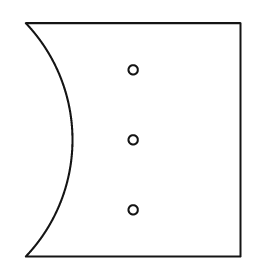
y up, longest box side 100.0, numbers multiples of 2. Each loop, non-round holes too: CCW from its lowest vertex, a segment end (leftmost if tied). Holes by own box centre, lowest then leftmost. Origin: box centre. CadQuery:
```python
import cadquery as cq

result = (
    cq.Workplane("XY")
    .moveTo(-46.0, -50.0)
    .lineTo(46.0, -50.0)
    .lineTo(46.0, 50.0)
    .lineTo(-46.0, 50.0)
    .threePointArc((-26.0, 0.0), (-46.0, -50.0))
    .close()
    .moveTo(0.0, -30.0)
    .circle(2.0)
    .moveTo(0.0, 0.0)
    .circle(2.0)
    .moveTo(0.0, 30.0)
    .circle(2.0)
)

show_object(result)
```